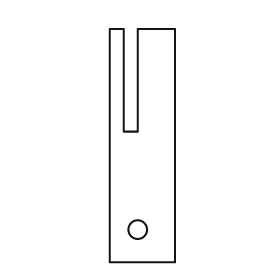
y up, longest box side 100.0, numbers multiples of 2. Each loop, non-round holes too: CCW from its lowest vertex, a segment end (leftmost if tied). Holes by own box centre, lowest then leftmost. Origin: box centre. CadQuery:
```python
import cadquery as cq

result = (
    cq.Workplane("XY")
    .moveTo(-14.0, -50.0)
    .lineTo(14.0, -50.0)
    .lineTo(14.0, 50.0)
    .lineTo(-2.0, 50.0)
    .lineTo(-2.0, 6.0)
    .lineTo(-8.0, 6.0)
    .lineTo(-8.0, 50.0)
    .lineTo(-14.0, 50.0)
    .close()
    .moveTo(-2.0, -36.0)
    .circle(4.0)
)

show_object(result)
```